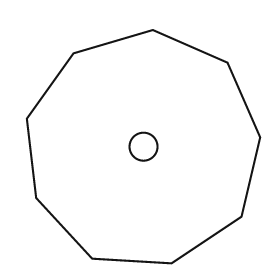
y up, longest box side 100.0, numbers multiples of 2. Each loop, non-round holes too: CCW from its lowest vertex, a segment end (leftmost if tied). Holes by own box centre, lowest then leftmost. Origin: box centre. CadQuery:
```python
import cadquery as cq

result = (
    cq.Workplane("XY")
    .moveTo(12.0, -50.0)
    .lineTo(42.0, -30.0)
    .lineTo(50.0, 4.0)
    .lineTo(36.0, 36.0)
    .lineTo(4.0, 50.0)
    .lineTo(-30.0, 40.0)
    .lineTo(-50.0, 12.0)
    .lineTo(-46.0, -22.0)
    .lineTo(-22.0, -48.0)
    .close()
    .moveTo(0.0, 0.0)
    .circle(6.0)
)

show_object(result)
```